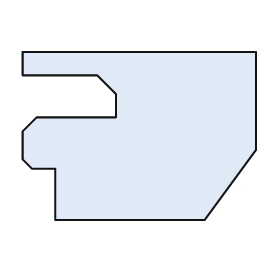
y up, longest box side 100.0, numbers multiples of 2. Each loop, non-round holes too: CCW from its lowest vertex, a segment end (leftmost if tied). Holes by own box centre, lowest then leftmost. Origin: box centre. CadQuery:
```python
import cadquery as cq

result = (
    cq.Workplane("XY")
    .moveTo(-36.0, -36.0)
    .lineTo(28.0, -36.0)
    .lineTo(50.0, -6.0)
    .lineTo(50.0, 36.0)
    .lineTo(-50.0, 36.0)
    .lineTo(-50.0, 26.0)
    .lineTo(-18.0, 26.0)
    .lineTo(-10.0, 18.0)
    .lineTo(-10.0, 8.0)
    .lineTo(-44.0, 8.0)
    .lineTo(-50.0, 2.0)
    .lineTo(-50.0, -10.0)
    .lineTo(-46.0, -14.0)
    .lineTo(-36.0, -14.0)
    .close()
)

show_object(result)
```